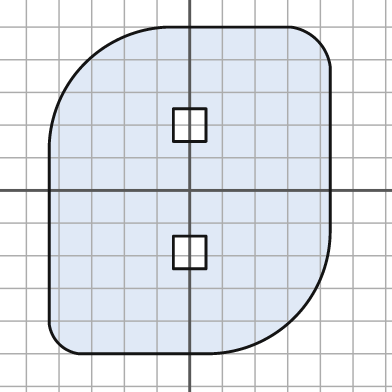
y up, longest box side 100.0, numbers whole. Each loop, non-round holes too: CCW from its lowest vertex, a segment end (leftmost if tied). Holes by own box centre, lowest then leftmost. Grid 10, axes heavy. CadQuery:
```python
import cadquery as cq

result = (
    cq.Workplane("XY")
    .moveTo(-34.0, -50.0)
    .lineTo(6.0, -50.0)
    .threePointArc((32.0, -39.0), (43.0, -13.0))
    .lineTo(43.0, 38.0)
    .threePointArc((39.0, 46.0), (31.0, 50.0))
    .lineTo(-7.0, 50.0)
    .threePointArc((-32.0, 39.0), (-43.0, 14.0))
    .lineTo(-43.0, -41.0)
    .threePointArc((-40.0, -47.0), (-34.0, -50.0))
    .close()
    .moveTo(-5.0, -24.0)
    .lineTo(5.0, -24.0)
    .lineTo(5.0, -14.0)
    .lineTo(-5.0, -14.0)
    .close()
    .moveTo(-5.0, 15.0)
    .lineTo(5.0, 15.0)
    .lineTo(5.0, 25.0)
    .lineTo(-5.0, 25.0)
    .close()
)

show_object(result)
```